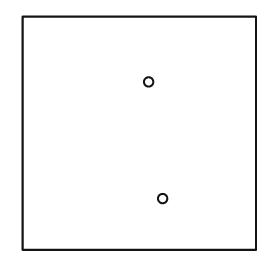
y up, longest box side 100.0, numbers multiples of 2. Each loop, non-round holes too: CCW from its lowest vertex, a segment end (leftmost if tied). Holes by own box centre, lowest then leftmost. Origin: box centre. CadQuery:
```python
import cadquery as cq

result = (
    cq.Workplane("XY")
    .moveTo(-50.0, -50.0)
    .lineTo(50.0, -50.0)
    .lineTo(50.0, 50.0)
    .lineTo(-50.0, 50.0)
    .close()
    .moveTo(10.0, -28.0)
    .circle(2.0)
    .moveTo(4.0, 22.0)
    .circle(2.0)
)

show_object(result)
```